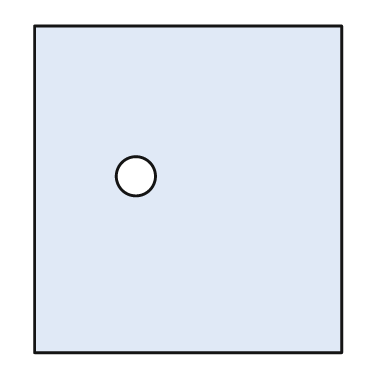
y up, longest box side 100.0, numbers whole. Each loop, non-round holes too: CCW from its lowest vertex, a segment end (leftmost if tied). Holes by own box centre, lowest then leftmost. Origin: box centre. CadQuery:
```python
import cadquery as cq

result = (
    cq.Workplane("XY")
    .moveTo(-47.0, -50.0)
    .lineTo(47.0, -50.0)
    .lineTo(47.0, 50.0)
    .lineTo(-47.0, 50.0)
    .close()
    .moveTo(-16.0, 4.0)
    .circle(6.0)
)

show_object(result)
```